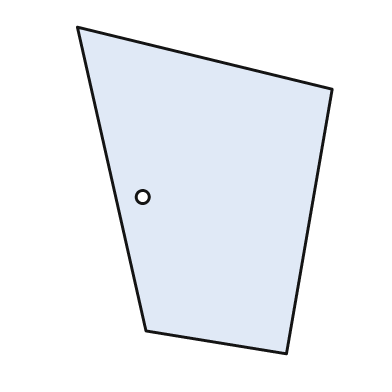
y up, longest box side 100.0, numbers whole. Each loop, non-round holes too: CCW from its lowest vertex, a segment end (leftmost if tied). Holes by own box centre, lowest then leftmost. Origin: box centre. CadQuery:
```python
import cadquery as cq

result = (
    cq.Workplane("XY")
    .moveTo(25.0, -50.0)
    .lineTo(39.0, 31.0)
    .lineTo(-39.0, 50.0)
    .lineTo(-18.0, -43.0)
    .close()
    .moveTo(-19.0, -2.0)
    .circle(2.0)
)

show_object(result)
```